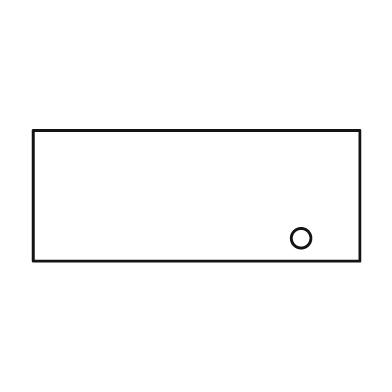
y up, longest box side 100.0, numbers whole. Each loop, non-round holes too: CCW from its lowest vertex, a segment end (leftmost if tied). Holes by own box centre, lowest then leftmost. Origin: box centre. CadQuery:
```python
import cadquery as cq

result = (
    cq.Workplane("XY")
    .moveTo(-50.0, -20.0)
    .lineTo(50.0, -20.0)
    .lineTo(50.0, 20.0)
    .lineTo(-50.0, 20.0)
    .close()
    .moveTo(32.0, -13.0)
    .circle(3.0)
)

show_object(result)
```